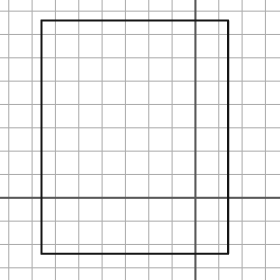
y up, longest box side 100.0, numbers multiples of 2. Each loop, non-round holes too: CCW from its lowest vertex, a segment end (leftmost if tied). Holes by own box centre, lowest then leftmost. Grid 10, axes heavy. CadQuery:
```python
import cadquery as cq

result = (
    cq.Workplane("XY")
    .moveTo(-66.0, -24.0)
    .lineTo(14.0, -24.0)
    .lineTo(14.0, 76.0)
    .lineTo(-66.0, 76.0)
    .close()
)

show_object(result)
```